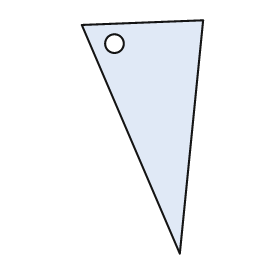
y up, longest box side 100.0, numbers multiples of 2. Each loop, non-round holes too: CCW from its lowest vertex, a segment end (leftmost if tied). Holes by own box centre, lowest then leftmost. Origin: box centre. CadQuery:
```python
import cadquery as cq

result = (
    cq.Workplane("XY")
    .moveTo(16.0, -50.0)
    .lineTo(26.0, 50.0)
    .lineTo(-26.0, 48.0)
    .close()
    .moveTo(-12.0, 40.0)
    .circle(4.0)
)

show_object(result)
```